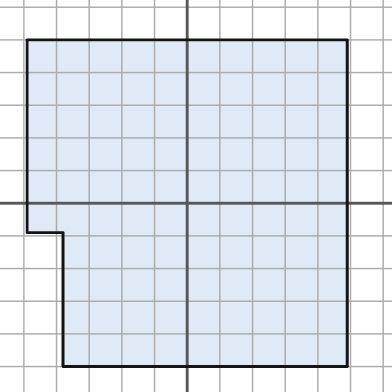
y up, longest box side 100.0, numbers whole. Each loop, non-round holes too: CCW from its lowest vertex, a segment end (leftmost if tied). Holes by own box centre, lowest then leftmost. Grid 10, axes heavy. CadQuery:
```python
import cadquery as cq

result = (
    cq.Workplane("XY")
    .moveTo(-38.0, -50.0)
    .lineTo(49.0, -50.0)
    .lineTo(49.0, 50.0)
    .lineTo(-49.0, 50.0)
    .lineTo(-49.0, -9.0)
    .lineTo(-38.0, -9.0)
    .close()
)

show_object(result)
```